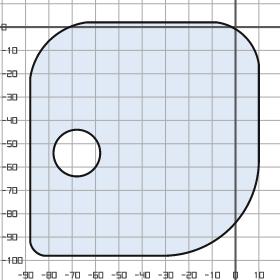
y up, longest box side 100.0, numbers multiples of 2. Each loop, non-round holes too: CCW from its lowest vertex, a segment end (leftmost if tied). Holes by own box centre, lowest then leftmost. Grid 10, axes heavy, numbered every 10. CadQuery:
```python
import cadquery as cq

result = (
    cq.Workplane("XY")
    .moveTo(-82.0, -98.0)
    .lineTo(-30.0, -98.0)
    .threePointArc((-2.0, -86.0), (10.0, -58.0))
    .lineTo(10.0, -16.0)
    .threePointArc((4.0, -4.0), (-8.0, 2.0))
    .lineTo(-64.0, 2.0)
    .threePointArc((-80.0, -6.0), (-88.0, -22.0))
    .lineTo(-88.0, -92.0)
    .threePointArc((-86.0, -96.0), (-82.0, -98.0))
    .close()
    .moveTo(-68.0, -54.0)
    .circle(10.0)
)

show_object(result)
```